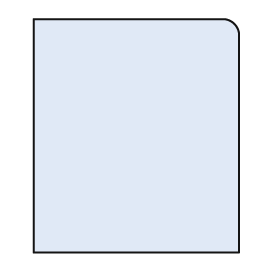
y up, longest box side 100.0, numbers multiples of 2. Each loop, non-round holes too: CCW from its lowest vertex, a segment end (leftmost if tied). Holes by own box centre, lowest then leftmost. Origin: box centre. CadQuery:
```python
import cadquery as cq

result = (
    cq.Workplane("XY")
    .moveTo(-44.0, -50.0)
    .lineTo(44.0, -50.0)
    .lineTo(44.0, 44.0)
    .threePointArc((42.0, 48.0), (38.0, 50.0))
    .lineTo(-44.0, 50.0)
    .close()
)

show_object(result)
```